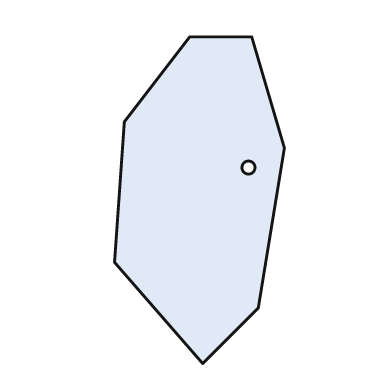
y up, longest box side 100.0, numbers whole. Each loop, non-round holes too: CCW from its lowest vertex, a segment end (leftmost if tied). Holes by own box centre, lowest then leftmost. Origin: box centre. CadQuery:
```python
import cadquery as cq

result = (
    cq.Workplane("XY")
    .moveTo(1.0, -50.0)
    .lineTo(18.0, -33.0)
    .lineTo(26.0, 16.0)
    .lineTo(16.0, 50.0)
    .lineTo(-3.0, 50.0)
    .lineTo(-23.0, 24.0)
    .lineTo(-26.0, -19.0)
    .close()
    .moveTo(15.0, 10.0)
    .circle(2.0)
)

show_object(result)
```